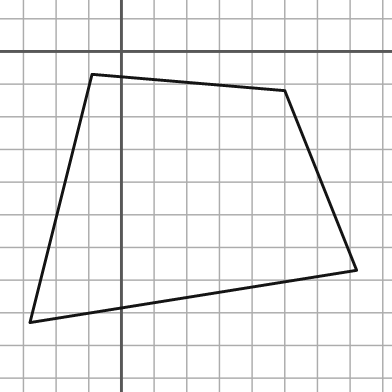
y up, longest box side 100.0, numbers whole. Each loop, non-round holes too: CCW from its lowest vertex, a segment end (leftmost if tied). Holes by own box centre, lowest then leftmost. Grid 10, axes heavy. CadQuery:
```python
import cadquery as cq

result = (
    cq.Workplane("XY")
    .moveTo(-28.0, -83.0)
    .lineTo(72.0, -67.0)
    .lineTo(50.0, -12.0)
    .lineTo(-9.0, -7.0)
    .close()
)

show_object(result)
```